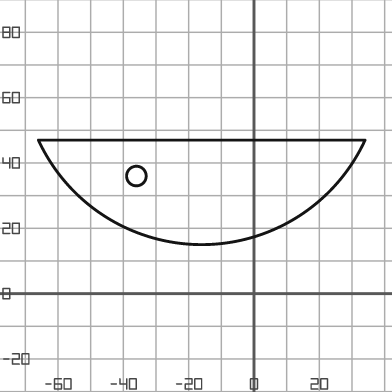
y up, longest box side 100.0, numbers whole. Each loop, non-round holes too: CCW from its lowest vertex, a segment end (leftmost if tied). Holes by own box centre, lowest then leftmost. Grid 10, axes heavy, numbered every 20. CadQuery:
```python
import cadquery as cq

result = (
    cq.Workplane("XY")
    .moveTo(-66.0, 47.0)
    .threePointArc((-16.0, 15.0), (34.0, 47.0))
    .close()
    .moveTo(-36.0, 36.0)
    .circle(3.0)
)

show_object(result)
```